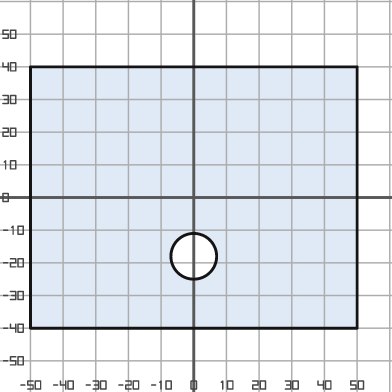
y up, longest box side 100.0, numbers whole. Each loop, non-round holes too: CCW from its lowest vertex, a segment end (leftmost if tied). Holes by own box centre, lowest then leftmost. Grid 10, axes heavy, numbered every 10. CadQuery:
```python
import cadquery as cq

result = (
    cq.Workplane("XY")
    .moveTo(-50.0, -40.0)
    .lineTo(50.0, -40.0)
    .lineTo(50.0, 40.0)
    .lineTo(-50.0, 40.0)
    .close()
    .moveTo(0.0, -18.0)
    .circle(7.0)
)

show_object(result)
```